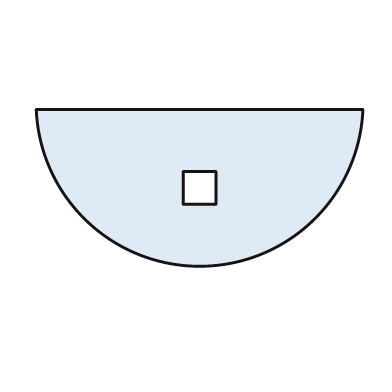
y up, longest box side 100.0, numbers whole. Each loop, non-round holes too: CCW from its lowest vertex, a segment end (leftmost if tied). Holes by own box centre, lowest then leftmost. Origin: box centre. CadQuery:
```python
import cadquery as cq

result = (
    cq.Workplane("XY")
    .moveTo(-50.0, 24.0)
    .threePointArc((0.0, -24.0), (50.0, 24.0))
    .close()
    .moveTo(-5.0, -5.0)
    .lineTo(5.0, -5.0)
    .lineTo(5.0, 5.0)
    .lineTo(-5.0, 5.0)
    .close()
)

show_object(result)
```